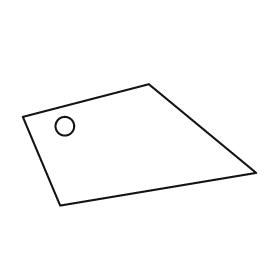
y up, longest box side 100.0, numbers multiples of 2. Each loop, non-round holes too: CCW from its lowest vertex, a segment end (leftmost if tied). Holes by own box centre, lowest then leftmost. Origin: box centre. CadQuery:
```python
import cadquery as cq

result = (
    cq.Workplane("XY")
    .moveTo(-34.0, -26.0)
    .lineTo(50.0, -12.0)
    .lineTo(4.0, 26.0)
    .lineTo(-50.0, 12.0)
    .close()
    .moveTo(-32.0, 8.0)
    .circle(4.0)
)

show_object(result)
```